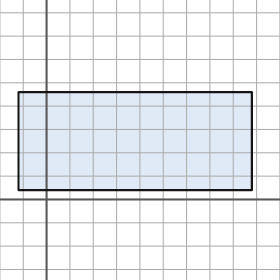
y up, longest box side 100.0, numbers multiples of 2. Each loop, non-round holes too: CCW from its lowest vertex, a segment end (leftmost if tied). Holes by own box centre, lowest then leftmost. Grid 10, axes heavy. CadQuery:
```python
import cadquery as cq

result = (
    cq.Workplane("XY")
    .moveTo(-12.0, 4.0)
    .lineTo(88.0, 4.0)
    .lineTo(88.0, 46.0)
    .lineTo(-12.0, 46.0)
    .close()
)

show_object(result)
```